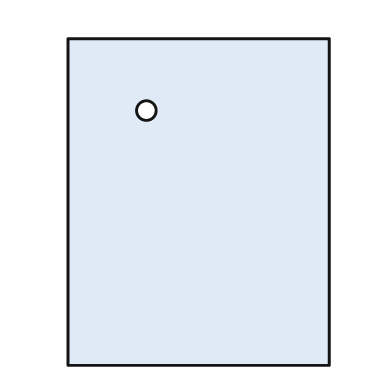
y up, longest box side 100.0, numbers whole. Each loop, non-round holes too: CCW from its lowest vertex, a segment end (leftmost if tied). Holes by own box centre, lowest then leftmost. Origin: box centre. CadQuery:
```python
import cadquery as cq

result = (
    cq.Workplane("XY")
    .moveTo(-40.0, -50.0)
    .lineTo(40.0, -50.0)
    .lineTo(40.0, 50.0)
    .lineTo(-40.0, 50.0)
    .close()
    .moveTo(-16.0, 28.0)
    .circle(3.0)
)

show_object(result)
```